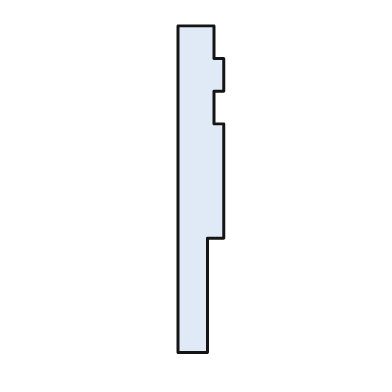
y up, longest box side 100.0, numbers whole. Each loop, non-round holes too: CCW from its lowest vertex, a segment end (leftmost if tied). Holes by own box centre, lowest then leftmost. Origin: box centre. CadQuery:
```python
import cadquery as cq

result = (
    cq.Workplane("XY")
    .moveTo(-7.0, -50.0)
    .lineTo(2.0, -50.0)
    .lineTo(2.0, -15.0)
    .lineTo(7.0, -15.0)
    .lineTo(7.0, 20.0)
    .lineTo(4.0, 20.0)
    .lineTo(4.0, 30.0)
    .lineTo(7.0, 30.0)
    .lineTo(7.0, 40.0)
    .lineTo(4.0, 40.0)
    .lineTo(4.0, 50.0)
    .lineTo(-7.0, 50.0)
    .close()
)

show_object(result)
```